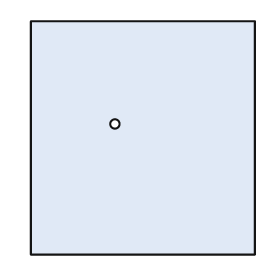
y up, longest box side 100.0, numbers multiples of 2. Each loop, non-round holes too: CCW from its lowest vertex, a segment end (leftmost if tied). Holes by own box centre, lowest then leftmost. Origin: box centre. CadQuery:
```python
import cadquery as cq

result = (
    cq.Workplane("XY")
    .moveTo(-48.0, -50.0)
    .lineTo(48.0, -50.0)
    .lineTo(48.0, 50.0)
    .lineTo(-48.0, 50.0)
    .close()
    .moveTo(-12.0, 6.0)
    .circle(2.0)
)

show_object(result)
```